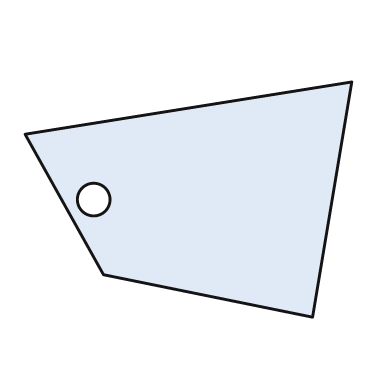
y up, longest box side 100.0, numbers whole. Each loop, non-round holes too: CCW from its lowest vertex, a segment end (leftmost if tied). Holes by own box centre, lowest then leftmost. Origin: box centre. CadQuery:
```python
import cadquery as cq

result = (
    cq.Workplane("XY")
    .moveTo(38.0, -36.0)
    .lineTo(50.0, 36.0)
    .lineTo(-50.0, 20.0)
    .lineTo(-26.0, -23.0)
    .close()
    .moveTo(-29.0, 0.0)
    .circle(5.0)
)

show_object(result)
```